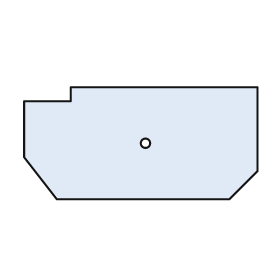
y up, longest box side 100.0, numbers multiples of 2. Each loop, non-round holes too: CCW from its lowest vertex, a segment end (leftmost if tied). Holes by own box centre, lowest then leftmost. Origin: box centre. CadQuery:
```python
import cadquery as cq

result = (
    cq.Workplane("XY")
    .moveTo(-36.0, -24.0)
    .lineTo(38.0, -24.0)
    .lineTo(50.0, -12.0)
    .lineTo(50.0, 24.0)
    .lineTo(-30.0, 24.0)
    .lineTo(-30.0, 18.0)
    .lineTo(-50.0, 18.0)
    .lineTo(-50.0, -6.0)
    .close()
    .moveTo(2.0, 0.0)
    .circle(2.0)
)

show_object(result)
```